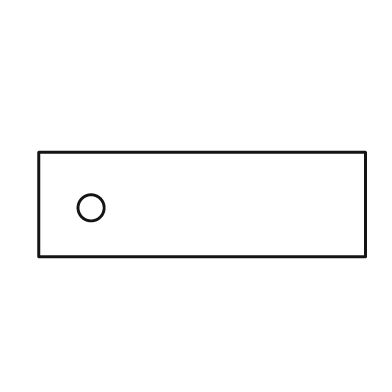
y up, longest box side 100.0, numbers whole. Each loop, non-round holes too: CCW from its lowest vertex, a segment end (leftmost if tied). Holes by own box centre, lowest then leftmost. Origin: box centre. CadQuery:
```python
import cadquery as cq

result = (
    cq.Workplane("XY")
    .moveTo(-50.0, -16.0)
    .lineTo(50.0, -16.0)
    .lineTo(50.0, 16.0)
    .lineTo(-50.0, 16.0)
    .close()
    .moveTo(-34.0, -1.0)
    .circle(4.0)
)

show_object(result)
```